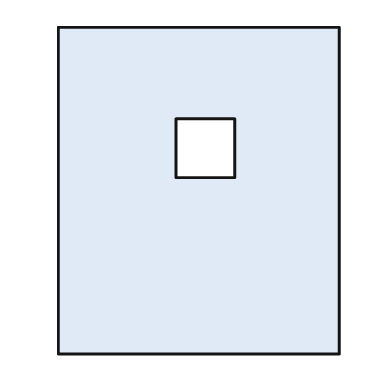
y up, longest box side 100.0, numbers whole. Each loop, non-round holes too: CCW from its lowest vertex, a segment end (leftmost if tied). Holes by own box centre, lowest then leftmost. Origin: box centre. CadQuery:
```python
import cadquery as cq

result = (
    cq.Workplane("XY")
    .moveTo(-43.0, -50.0)
    .lineTo(43.0, -50.0)
    .lineTo(43.0, 50.0)
    .lineTo(-43.0, 50.0)
    .close()
    .moveTo(-7.0, 4.0)
    .lineTo(11.0, 4.0)
    .lineTo(11.0, 22.0)
    .lineTo(-7.0, 22.0)
    .close()
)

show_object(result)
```